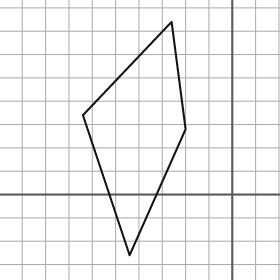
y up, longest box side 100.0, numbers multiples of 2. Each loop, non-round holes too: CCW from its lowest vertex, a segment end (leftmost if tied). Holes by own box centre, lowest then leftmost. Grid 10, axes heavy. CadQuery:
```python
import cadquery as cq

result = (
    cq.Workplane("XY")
    .moveTo(-44.0, -26.0)
    .lineTo(-20.0, 28.0)
    .lineTo(-26.0, 74.0)
    .lineTo(-64.0, 34.0)
    .close()
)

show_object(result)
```